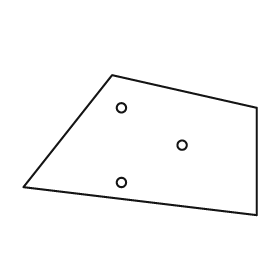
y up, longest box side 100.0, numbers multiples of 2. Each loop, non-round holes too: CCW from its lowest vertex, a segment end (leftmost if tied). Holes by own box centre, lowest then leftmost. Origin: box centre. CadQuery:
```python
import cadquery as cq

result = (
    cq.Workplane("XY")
    .moveTo(50.0, -30.0)
    .lineTo(50.0, 16.0)
    .lineTo(-12.0, 30.0)
    .lineTo(-50.0, -18.0)
    .close()
    .moveTo(-8.0, -16.0)
    .circle(2.0)
    .moveTo(18.0, 0.0)
    .circle(2.0)
    .moveTo(-8.0, 16.0)
    .circle(2.0)
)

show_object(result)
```